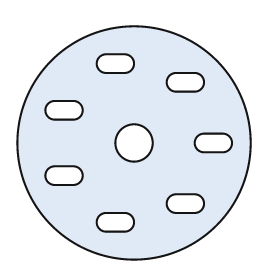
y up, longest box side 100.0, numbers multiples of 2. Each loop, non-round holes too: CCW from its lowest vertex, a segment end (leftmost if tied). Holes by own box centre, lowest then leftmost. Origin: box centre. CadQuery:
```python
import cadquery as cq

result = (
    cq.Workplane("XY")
    .moveTo(0.0, 0.0)
    .circle(50.0)
    .moveTo(-12.0, -38.0)
    .lineTo(-4.0, -38.0)
    .threePointArc((0.0, -34.0), (-4.0, -30.0))
    .lineTo(-12.0, -30.0)
    .threePointArc((-16.0, -34.0), (-12.0, -38.0))
    .close()
    .moveTo(18.0, -30.0)
    .lineTo(26.0, -30.0)
    .threePointArc((30.0, -26.0), (26.0, -22.0))
    .lineTo(18.0, -22.0)
    .threePointArc((14.0, -26.0), (18.0, -30.0))
    .close()
    .moveTo(-34.0, -18.0)
    .lineTo(-26.0, -18.0)
    .threePointArc((-22.0, -14.0), (-26.0, -10.0))
    .lineTo(-34.0, -10.0)
    .threePointArc((-38.0, -14.0), (-34.0, -18.0))
    .close()
    .moveTo(0.0, 0.0)
    .circle(8.0)
    .moveTo(30.0, -4.0)
    .lineTo(38.0, -4.0)
    .threePointArc((42.0, 0.0), (38.0, 4.0))
    .lineTo(30.0, 4.0)
    .threePointArc((26.0, 0.0), (30.0, -4.0))
    .close()
    .moveTo(-34.0, 10.0)
    .lineTo(-26.0, 10.0)
    .threePointArc((-22.0, 14.0), (-26.0, 18.0))
    .lineTo(-34.0, 18.0)
    .threePointArc((-38.0, 14.0), (-34.0, 10.0))
    .close()
    .moveTo(18.0, 22.0)
    .lineTo(26.0, 22.0)
    .threePointArc((30.0, 26.0), (26.0, 30.0))
    .lineTo(18.0, 30.0)
    .threePointArc((14.0, 26.0), (18.0, 22.0))
    .close()
    .moveTo(-12.0, 30.0)
    .lineTo(-4.0, 30.0)
    .threePointArc((0.0, 34.0), (-4.0, 38.0))
    .lineTo(-12.0, 38.0)
    .threePointArc((-16.0, 34.0), (-12.0, 30.0))
    .close()
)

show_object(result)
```